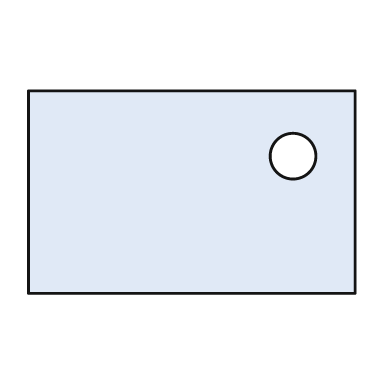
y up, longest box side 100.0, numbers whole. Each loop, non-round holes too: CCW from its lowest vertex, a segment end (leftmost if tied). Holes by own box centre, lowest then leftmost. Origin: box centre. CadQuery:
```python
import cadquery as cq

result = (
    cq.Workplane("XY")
    .moveTo(-50.0, -31.0)
    .lineTo(50.0, -31.0)
    .lineTo(50.0, 31.0)
    .lineTo(-50.0, 31.0)
    .close()
    .moveTo(31.0, 11.0)
    .circle(7.0)
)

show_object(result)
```